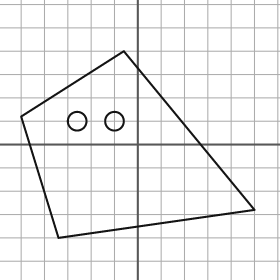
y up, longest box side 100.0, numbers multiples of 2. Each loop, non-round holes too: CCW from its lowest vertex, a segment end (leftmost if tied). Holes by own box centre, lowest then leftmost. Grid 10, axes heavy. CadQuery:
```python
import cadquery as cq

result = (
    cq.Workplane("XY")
    .moveTo(-34.0, -40.0)
    .lineTo(50.0, -28.0)
    .lineTo(-6.0, 40.0)
    .lineTo(-50.0, 12.0)
    .close()
    .moveTo(-26.0, 10.0)
    .circle(4.0)
    .moveTo(-10.0, 10.0)
    .circle(4.0)
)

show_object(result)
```